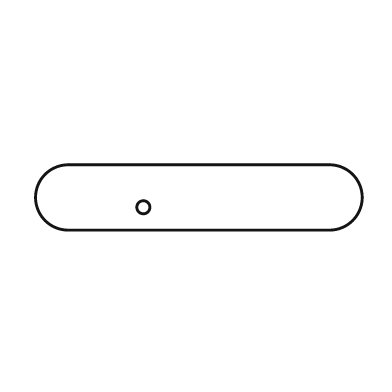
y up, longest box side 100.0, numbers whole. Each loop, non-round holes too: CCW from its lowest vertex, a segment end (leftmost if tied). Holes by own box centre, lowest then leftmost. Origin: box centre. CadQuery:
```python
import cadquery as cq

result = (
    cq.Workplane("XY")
    .moveTo(-40.0, -10.0)
    .lineTo(40.0, -10.0)
    .threePointArc((50.0, 0.0), (40.0, 10.0))
    .lineTo(-40.0, 10.0)
    .threePointArc((-50.0, 0.0), (-40.0, -10.0))
    .close()
    .moveTo(-17.0, -3.0)
    .circle(2.0)
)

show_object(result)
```